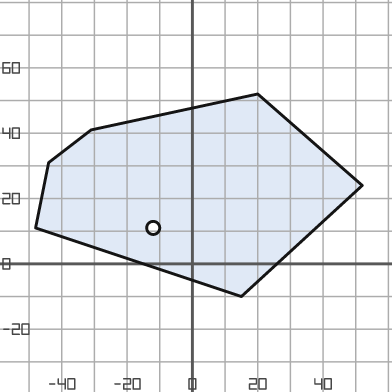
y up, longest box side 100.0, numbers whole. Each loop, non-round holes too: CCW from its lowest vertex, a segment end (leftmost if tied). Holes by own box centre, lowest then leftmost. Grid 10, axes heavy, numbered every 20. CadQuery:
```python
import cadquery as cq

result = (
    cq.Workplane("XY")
    .moveTo(15.0, -10.0)
    .lineTo(52.0, 24.0)
    .lineTo(20.0, 52.0)
    .lineTo(-31.0, 41.0)
    .lineTo(-44.0, 31.0)
    .lineTo(-48.0, 11.0)
    .close()
    .moveTo(-12.0, 11.0)
    .circle(2.0)
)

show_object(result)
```